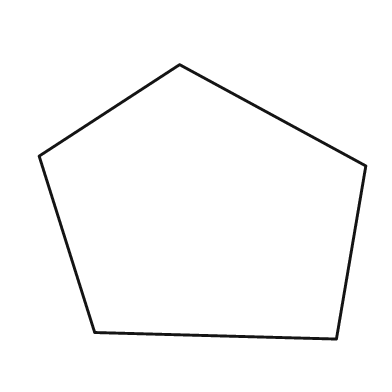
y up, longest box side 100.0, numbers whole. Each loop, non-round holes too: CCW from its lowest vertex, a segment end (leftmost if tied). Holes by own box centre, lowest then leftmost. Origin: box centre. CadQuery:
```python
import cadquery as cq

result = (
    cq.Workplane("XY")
    .moveTo(41.0, -42.0)
    .lineTo(50.0, 11.0)
    .lineTo(-7.0, 42.0)
    .lineTo(-50.0, 14.0)
    .lineTo(-33.0, -40.0)
    .close()
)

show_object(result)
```